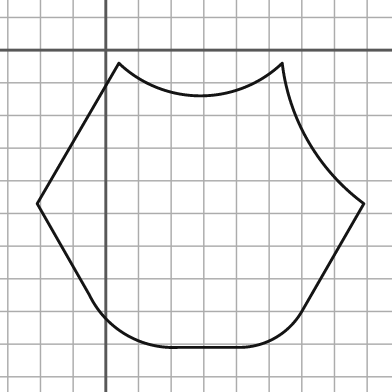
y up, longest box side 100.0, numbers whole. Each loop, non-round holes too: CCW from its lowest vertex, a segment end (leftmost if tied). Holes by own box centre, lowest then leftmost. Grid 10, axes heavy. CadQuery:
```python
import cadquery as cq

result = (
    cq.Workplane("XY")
    .moveTo(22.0, -91.0)
    .lineTo(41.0, -91.0)
    .threePointArc((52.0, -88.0), (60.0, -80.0))
    .lineTo(79.0, -47.0)
    .threePointArc((62.0, -28.0), (54.0, -4.0))
    .threePointArc((29.0, -14.0), (4.0, -4.0))
    .lineTo(-21.0, -47.0)
    .lineTo(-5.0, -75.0)
    .threePointArc((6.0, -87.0), (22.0, -91.0))
    .close()
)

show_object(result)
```